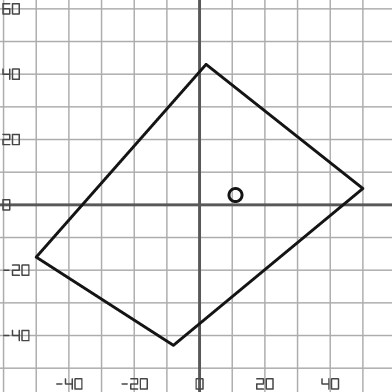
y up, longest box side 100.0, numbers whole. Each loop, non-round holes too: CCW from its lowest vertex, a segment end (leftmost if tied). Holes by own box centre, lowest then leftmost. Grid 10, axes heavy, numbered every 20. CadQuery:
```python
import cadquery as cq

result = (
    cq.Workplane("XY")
    .moveTo(-8.0, -43.0)
    .lineTo(50.0, 5.0)
    .lineTo(2.0, 43.0)
    .lineTo(-50.0, -16.0)
    .close()
    .moveTo(11.0, 3.0)
    .circle(2.0)
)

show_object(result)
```